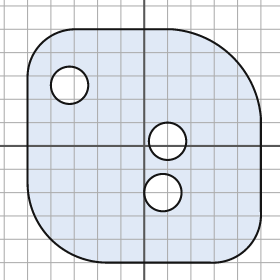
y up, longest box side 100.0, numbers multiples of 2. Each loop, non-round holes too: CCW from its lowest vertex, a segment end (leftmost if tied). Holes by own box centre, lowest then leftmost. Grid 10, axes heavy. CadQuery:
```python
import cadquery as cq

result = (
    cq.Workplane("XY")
    .moveTo(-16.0, -50.0)
    .lineTo(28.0, -50.0)
    .threePointArc((44.0, -44.0), (50.0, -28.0))
    .lineTo(50.0, 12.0)
    .threePointArc((38.0, 38.0), (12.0, 50.0))
    .lineTo(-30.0, 50.0)
    .threePointArc((-44.0, 44.0), (-50.0, 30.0))
    .lineTo(-50.0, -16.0)
    .threePointArc((-40.0, -40.0), (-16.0, -50.0))
    .close()
    .moveTo(8.0, -20.0)
    .circle(8.0)
    .moveTo(10.0, 2.0)
    .circle(8.0)
    .moveTo(-32.0, 26.0)
    .circle(8.0)
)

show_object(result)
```